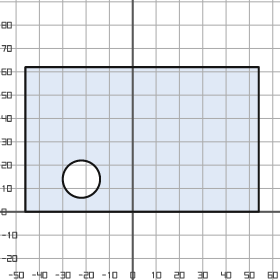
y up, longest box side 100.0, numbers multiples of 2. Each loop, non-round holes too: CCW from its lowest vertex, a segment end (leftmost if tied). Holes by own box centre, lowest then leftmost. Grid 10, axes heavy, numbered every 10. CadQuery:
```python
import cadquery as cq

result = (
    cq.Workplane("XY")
    .moveTo(-46.0, 0.0)
    .lineTo(54.0, 0.0)
    .lineTo(54.0, 62.0)
    .lineTo(-46.0, 62.0)
    .close()
    .moveTo(-22.0, 14.0)
    .circle(8.0)
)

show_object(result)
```